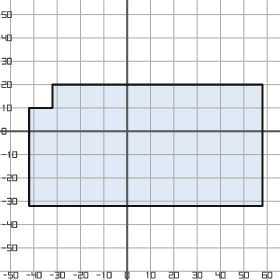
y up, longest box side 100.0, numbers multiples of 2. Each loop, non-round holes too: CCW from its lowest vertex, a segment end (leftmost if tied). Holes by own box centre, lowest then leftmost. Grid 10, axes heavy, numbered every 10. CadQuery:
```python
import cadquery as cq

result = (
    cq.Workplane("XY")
    .moveTo(-42.0, -32.0)
    .lineTo(58.0, -32.0)
    .lineTo(58.0, 20.0)
    .lineTo(-32.0, 20.0)
    .lineTo(-32.0, 10.0)
    .lineTo(-42.0, 10.0)
    .close()
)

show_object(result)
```